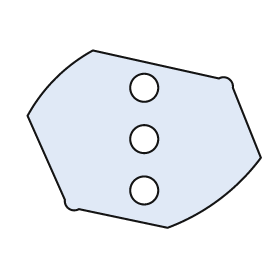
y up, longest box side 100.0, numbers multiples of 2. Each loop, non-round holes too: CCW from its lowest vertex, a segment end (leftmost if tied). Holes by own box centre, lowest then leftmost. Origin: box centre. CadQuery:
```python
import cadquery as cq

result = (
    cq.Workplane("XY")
    .moveTo(10.0, -38.0)
    .threePointArc((32.0, -26.0), (50.0, -8.0))
    .lineTo(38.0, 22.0)
    .threePointArc((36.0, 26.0), (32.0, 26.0))
    .lineTo(-22.0, 38.0)
    .threePointArc((-38.0, 26.0), (-50.0, 10.0))
    .lineTo(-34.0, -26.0)
    .threePointArc((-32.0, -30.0), (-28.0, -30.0))
    .close()
    .moveTo(0.0, -22.0)
    .circle(6.0)
    .moveTo(0.0, 0.0)
    .circle(6.0)
    .moveTo(0.0, 22.0)
    .circle(6.0)
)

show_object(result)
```